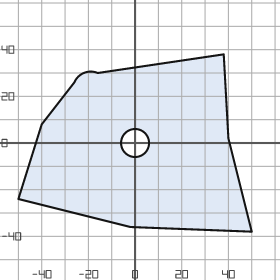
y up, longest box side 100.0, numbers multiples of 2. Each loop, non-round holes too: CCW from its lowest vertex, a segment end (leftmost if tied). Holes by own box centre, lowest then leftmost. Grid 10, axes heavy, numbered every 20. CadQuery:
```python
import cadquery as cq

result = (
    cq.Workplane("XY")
    .moveTo(50.0, -38.0)
    .lineTo(40.0, 2.0)
    .lineTo(38.0, 38.0)
    .lineTo(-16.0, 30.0)
    .threePointArc((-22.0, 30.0), (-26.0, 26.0))
    .lineTo(-40.0, 8.0)
    .lineTo(-50.0, -24.0)
    .lineTo(-2.0, -36.0)
    .close()
    .moveTo(0.0, 0.0)
    .circle(6.0)
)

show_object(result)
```